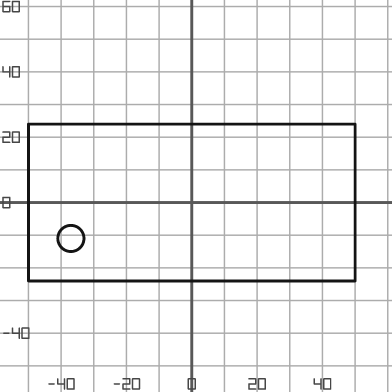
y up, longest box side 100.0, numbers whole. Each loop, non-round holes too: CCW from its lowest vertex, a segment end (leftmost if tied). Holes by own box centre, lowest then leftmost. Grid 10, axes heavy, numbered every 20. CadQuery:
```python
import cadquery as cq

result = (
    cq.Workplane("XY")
    .moveTo(-50.0, -24.0)
    .lineTo(50.0, -24.0)
    .lineTo(50.0, 24.0)
    .lineTo(-50.0, 24.0)
    .close()
    .moveTo(-37.0, -11.0)
    .circle(4.0)
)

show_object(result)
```